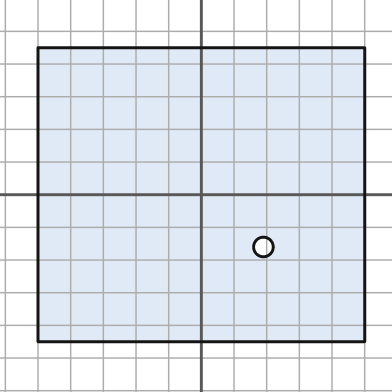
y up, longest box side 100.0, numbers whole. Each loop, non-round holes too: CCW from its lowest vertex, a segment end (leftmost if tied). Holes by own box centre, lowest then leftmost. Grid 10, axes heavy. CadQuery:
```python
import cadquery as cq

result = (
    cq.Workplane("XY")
    .moveTo(-50.0, -45.0)
    .lineTo(50.0, -45.0)
    .lineTo(50.0, 45.0)
    .lineTo(-50.0, 45.0)
    .close()
    .moveTo(19.0, -16.0)
    .circle(3.0)
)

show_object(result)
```